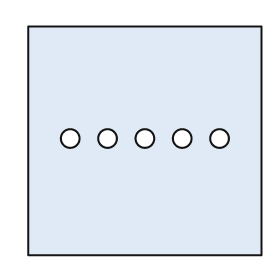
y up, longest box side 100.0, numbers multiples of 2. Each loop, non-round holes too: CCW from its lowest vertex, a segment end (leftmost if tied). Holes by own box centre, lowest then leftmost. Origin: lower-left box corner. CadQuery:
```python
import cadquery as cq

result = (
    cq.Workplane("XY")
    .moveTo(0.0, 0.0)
    .lineTo(100.0, 0.0)
    .lineTo(100.0, 98.0)
    .lineTo(0.0, 98.0)
    .close()
    .moveTo(18.0, 50.0)
    .circle(4.0)
    .moveTo(34.0, 50.0)
    .circle(4.0)
    .moveTo(50.0, 50.0)
    .circle(4.0)
    .moveTo(66.0, 50.0)
    .circle(4.0)
    .moveTo(82.0, 50.0)
    .circle(4.0)
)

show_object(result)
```